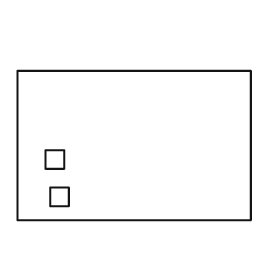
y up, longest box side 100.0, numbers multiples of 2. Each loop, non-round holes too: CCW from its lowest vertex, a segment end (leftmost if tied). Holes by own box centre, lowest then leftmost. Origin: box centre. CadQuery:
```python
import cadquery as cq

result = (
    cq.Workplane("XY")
    .moveTo(-50.0, -32.0)
    .lineTo(50.0, -32.0)
    .lineTo(50.0, 32.0)
    .lineTo(-50.0, 32.0)
    .close()
    .moveTo(-36.0, -26.0)
    .lineTo(-28.0, -26.0)
    .lineTo(-28.0, -18.0)
    .lineTo(-36.0, -18.0)
    .close()
    .moveTo(-38.0, -10.0)
    .lineTo(-30.0, -10.0)
    .lineTo(-30.0, -2.0)
    .lineTo(-38.0, -2.0)
    .close()
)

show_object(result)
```